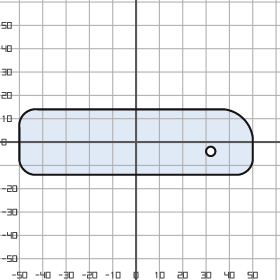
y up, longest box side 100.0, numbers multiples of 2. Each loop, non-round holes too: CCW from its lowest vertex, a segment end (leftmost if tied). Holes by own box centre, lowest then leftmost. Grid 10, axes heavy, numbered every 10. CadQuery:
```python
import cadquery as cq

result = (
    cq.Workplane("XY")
    .moveTo(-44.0, -14.0)
    .lineTo(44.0, -14.0)
    .threePointArc((48.0, -12.0), (50.0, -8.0))
    .lineTo(50.0, 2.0)
    .threePointArc((46.0, 10.0), (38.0, 14.0))
    .lineTo(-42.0, 14.0)
    .threePointArc((-48.0, 12.0), (-50.0, 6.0))
    .lineTo(-50.0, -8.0)
    .threePointArc((-48.0, -12.0), (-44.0, -14.0))
    .close()
    .moveTo(32.0, -4.0)
    .circle(2.0)
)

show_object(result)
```